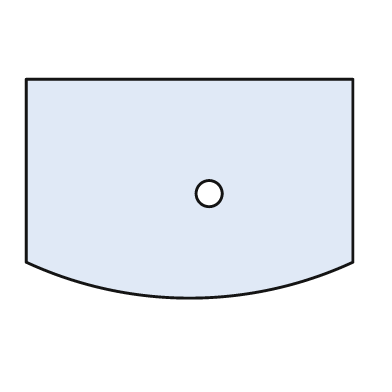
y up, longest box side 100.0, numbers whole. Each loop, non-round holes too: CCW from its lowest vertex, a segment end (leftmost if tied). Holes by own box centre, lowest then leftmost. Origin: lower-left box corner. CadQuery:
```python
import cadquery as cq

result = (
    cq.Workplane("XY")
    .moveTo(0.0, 11.0)
    .threePointArc((50.0, 0.0), (100.0, 11.0))
    .lineTo(100.0, 67.0)
    .lineTo(0.0, 67.0)
    .close()
    .moveTo(56.0, 32.0)
    .circle(4.0)
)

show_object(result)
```